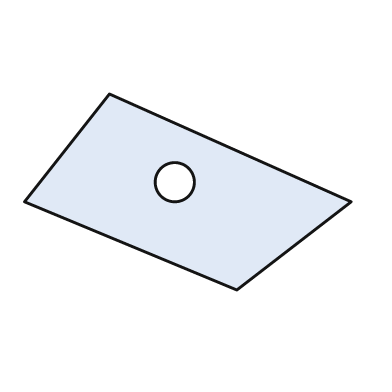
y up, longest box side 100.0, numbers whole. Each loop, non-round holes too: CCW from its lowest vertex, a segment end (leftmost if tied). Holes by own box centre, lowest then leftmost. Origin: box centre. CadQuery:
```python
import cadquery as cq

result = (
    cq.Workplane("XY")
    .moveTo(15.0, -30.0)
    .lineTo(50.0, -3.0)
    .lineTo(-24.0, 30.0)
    .lineTo(-50.0, -3.0)
    .close()
    .moveTo(-4.0, 3.0)
    .circle(6.0)
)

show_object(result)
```